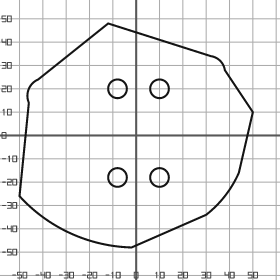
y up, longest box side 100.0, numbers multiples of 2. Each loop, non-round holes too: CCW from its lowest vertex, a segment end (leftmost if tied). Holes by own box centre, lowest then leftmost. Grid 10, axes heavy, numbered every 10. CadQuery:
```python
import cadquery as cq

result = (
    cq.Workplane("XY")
    .moveTo(-2.0, -48.0)
    .lineTo(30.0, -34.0)
    .threePointArc((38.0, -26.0), (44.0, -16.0))
    .lineTo(50.0, 10.0)
    .lineTo(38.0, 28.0)
    .threePointArc((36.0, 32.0), (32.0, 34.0))
    .lineTo(-12.0, 48.0)
    .lineTo(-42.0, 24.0)
    .threePointArc((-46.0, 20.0), (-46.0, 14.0))
    .lineTo(-50.0, -26.0)
    .threePointArc((-28.0, -42.0), (-2.0, -48.0))
    .close()
    .moveTo(-8.0, -18.0)
    .circle(4.0)
    .moveTo(10.0, -18.0)
    .circle(4.0)
    .moveTo(-8.0, 20.0)
    .circle(4.0)
    .moveTo(10.0, 20.0)
    .circle(4.0)
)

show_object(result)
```